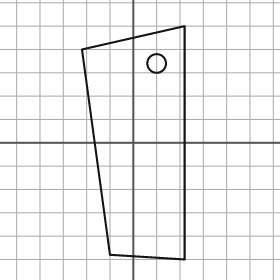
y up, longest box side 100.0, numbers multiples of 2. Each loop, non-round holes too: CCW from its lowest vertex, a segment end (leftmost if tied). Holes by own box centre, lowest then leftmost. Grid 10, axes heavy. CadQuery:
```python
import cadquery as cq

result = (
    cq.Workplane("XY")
    .moveTo(22.0, -50.0)
    .lineTo(22.0, 50.0)
    .lineTo(-22.0, 40.0)
    .lineTo(-10.0, -48.0)
    .close()
    .moveTo(10.0, 34.0)
    .circle(4.0)
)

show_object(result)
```